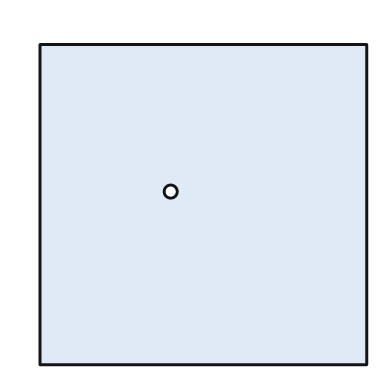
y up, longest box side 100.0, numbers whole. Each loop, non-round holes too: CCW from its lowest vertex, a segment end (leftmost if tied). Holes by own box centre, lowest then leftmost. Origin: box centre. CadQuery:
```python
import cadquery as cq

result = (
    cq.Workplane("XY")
    .moveTo(-50.0, -49.0)
    .lineTo(50.0, -49.0)
    .lineTo(50.0, 49.0)
    .lineTo(-50.0, 49.0)
    .close()
    .moveTo(-10.0, 4.0)
    .circle(2.0)
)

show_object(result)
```